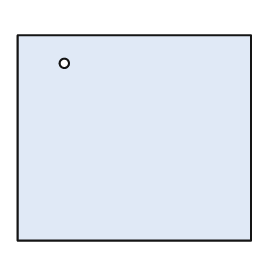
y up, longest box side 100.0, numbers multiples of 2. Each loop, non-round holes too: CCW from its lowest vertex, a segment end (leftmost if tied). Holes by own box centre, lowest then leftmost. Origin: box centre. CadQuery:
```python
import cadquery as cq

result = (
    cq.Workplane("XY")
    .moveTo(-50.0, -44.0)
    .lineTo(50.0, -44.0)
    .lineTo(50.0, 44.0)
    .lineTo(-50.0, 44.0)
    .close()
    .moveTo(-30.0, 32.0)
    .circle(2.0)
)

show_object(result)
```